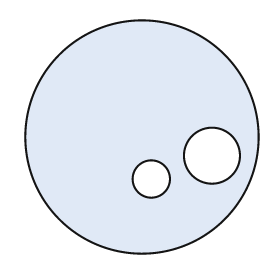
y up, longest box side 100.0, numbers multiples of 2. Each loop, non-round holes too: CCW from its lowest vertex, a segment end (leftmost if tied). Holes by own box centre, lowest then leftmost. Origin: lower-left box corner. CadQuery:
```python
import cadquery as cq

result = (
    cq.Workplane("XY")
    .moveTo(50.0, 50.0)
    .circle(50.0)
    .moveTo(54.0, 32.0)
    .circle(8.0)
    .moveTo(80.0, 42.0)
    .circle(12.0)
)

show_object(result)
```